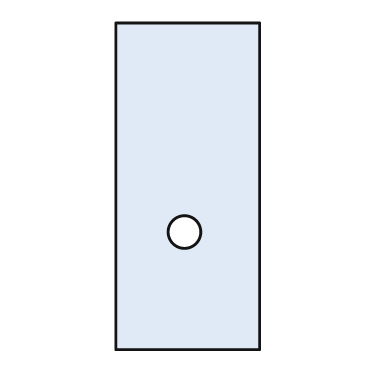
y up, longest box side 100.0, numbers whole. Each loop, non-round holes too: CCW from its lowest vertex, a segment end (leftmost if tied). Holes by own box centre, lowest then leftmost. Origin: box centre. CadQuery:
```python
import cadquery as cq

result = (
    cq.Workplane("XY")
    .moveTo(-22.0, -50.0)
    .lineTo(22.0, -50.0)
    .lineTo(22.0, 50.0)
    .lineTo(-22.0, 50.0)
    .close()
    .moveTo(-1.0, -14.0)
    .circle(5.0)
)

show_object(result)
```